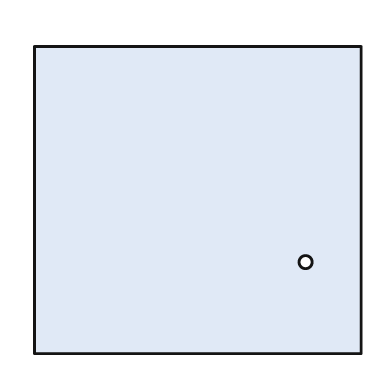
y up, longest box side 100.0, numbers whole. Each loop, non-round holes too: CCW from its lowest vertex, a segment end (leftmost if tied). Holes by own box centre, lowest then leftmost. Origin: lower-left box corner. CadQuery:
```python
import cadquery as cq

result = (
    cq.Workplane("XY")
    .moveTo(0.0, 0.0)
    .lineTo(100.0, 0.0)
    .lineTo(100.0, 94.0)
    .lineTo(0.0, 94.0)
    .close()
    .moveTo(83.0, 28.0)
    .circle(2.0)
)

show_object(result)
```